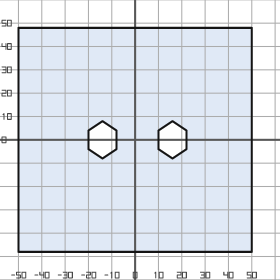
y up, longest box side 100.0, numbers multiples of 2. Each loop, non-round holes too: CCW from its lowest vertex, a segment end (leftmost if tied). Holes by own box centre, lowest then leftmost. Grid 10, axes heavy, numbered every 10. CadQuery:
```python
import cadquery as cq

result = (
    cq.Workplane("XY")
    .moveTo(-50.0, -48.0)
    .lineTo(50.0, -48.0)
    .lineTo(50.0, 48.0)
    .lineTo(-50.0, 48.0)
    .close()
    .moveTo(-14.0, -8.0)
    .lineTo(-8.0, -4.0)
    .lineTo(-8.0, 4.0)
    .lineTo(-14.0, 8.0)
    .lineTo(-20.0, 4.0)
    .lineTo(-20.0, -4.0)
    .close()
    .moveTo(16.0, -8.0)
    .lineTo(22.0, -4.0)
    .lineTo(22.0, 4.0)
    .lineTo(16.0, 8.0)
    .lineTo(10.0, 4.0)
    .lineTo(10.0, -4.0)
    .close()
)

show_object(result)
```